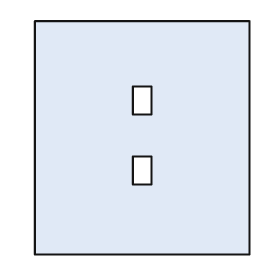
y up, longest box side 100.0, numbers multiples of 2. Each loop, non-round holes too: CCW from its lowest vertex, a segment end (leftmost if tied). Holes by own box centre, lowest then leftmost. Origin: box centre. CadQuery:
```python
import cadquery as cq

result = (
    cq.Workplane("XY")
    .moveTo(-46.0, -50.0)
    .lineTo(46.0, -50.0)
    .lineTo(46.0, 50.0)
    .lineTo(-46.0, 50.0)
    .close()
    .moveTo(-4.0, -20.0)
    .lineTo(4.0, -20.0)
    .lineTo(4.0, -8.0)
    .lineTo(-4.0, -8.0)
    .close()
    .moveTo(-4.0, 10.0)
    .lineTo(4.0, 10.0)
    .lineTo(4.0, 22.0)
    .lineTo(-4.0, 22.0)
    .close()
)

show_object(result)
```